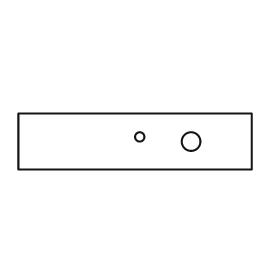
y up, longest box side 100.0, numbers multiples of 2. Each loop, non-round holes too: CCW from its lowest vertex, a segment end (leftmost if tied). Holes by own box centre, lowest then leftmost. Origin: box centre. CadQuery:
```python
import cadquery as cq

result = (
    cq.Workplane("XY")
    .moveTo(-50.0, -12.0)
    .lineTo(50.0, -12.0)
    .lineTo(50.0, 12.0)
    .lineTo(-50.0, 12.0)
    .close()
    .moveTo(24.0, 0.0)
    .circle(4.0)
    .moveTo(2.0, 2.0)
    .circle(2.0)
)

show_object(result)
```